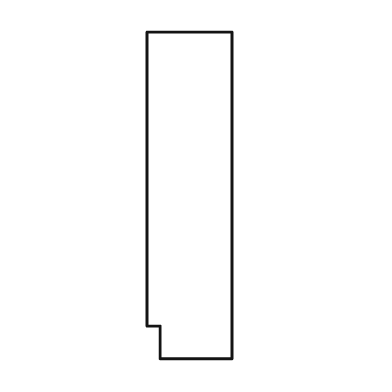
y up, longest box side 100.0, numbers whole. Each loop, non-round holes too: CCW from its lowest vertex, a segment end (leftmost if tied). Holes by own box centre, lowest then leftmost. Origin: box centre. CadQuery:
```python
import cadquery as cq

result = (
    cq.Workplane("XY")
    .moveTo(-9.0, -50.0)
    .lineTo(13.0, -50.0)
    .lineTo(13.0, 50.0)
    .lineTo(-13.0, 50.0)
    .lineTo(-13.0, -40.0)
    .lineTo(-9.0, -40.0)
    .close()
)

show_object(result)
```